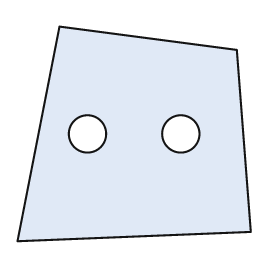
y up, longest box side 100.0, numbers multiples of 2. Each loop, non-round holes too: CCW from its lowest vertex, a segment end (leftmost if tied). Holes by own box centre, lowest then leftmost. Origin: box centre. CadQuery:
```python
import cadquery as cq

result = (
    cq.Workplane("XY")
    .moveTo(-50.0, -46.0)
    .lineTo(50.0, -42.0)
    .lineTo(44.0, 36.0)
    .lineTo(-32.0, 46.0)
    .close()
    .moveTo(-20.0, 0.0)
    .circle(8.0)
    .moveTo(20.0, 0.0)
    .circle(8.0)
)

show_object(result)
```